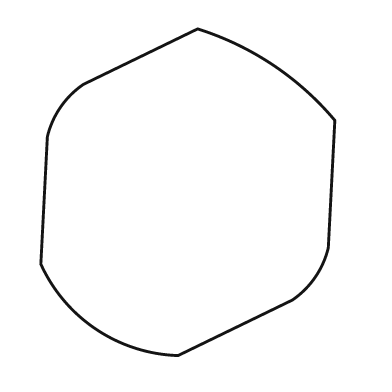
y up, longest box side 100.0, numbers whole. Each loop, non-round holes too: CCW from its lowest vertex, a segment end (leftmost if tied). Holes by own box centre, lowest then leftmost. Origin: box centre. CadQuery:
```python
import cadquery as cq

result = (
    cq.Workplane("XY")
    .moveTo(-3.0, -50.0)
    .lineTo(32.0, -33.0)
    .threePointArc((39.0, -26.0), (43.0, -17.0))
    .lineTo(45.0, 22.0)
    .threePointArc((26.0, 39.0), (3.0, 50.0))
    .lineTo(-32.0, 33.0)
    .threePointArc((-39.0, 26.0), (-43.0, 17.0))
    .lineTo(-45.0, -22.0)
    .threePointArc((-28.0, -42.0), (-3.0, -50.0))
    .close()
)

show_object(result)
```